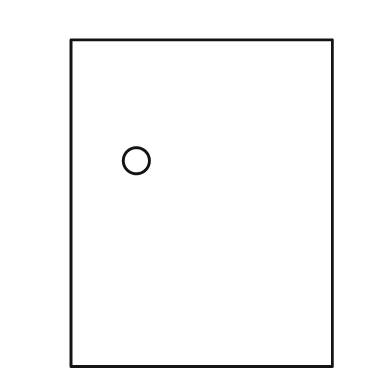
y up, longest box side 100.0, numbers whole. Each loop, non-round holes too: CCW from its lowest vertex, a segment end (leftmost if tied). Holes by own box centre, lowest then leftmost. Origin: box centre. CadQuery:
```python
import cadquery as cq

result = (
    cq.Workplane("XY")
    .moveTo(-40.0, -50.0)
    .lineTo(40.0, -50.0)
    .lineTo(40.0, 50.0)
    .lineTo(-40.0, 50.0)
    .close()
    .moveTo(-20.0, 13.0)
    .circle(4.0)
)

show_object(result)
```